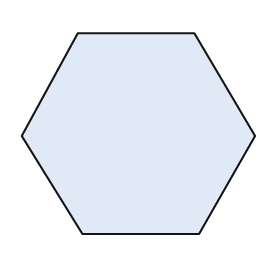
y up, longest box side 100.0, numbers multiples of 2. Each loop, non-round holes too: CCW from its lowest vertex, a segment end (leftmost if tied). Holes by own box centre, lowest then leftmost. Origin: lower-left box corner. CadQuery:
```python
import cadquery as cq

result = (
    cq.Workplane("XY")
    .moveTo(26.0, 0.0)
    .lineTo(76.0, 0.0)
    .lineTo(100.0, 42.0)
    .lineTo(74.0, 86.0)
    .lineTo(24.0, 86.0)
    .lineTo(0.0, 42.0)
    .close()
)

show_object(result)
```